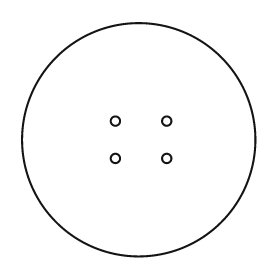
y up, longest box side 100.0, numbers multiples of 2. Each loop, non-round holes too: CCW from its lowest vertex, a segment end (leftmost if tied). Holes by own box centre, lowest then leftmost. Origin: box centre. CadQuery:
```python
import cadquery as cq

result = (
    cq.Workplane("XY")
    .moveTo(0.0, 0.0)
    .circle(50.0)
    .moveTo(-10.0, -8.0)
    .circle(2.0)
    .moveTo(12.0, -8.0)
    .circle(2.0)
    .moveTo(-10.0, 8.0)
    .circle(2.0)
    .moveTo(12.0, 8.0)
    .circle(2.0)
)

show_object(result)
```